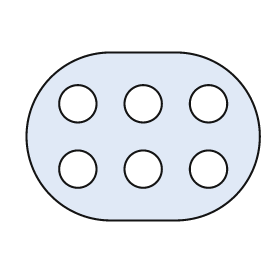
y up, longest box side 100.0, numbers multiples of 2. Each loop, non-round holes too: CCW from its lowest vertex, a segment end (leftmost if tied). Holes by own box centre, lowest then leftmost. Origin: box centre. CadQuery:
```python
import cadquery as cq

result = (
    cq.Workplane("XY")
    .moveTo(-14.0, -36.0)
    .lineTo(14.0, -36.0)
    .threePointArc((50.0, 0.0), (14.0, 36.0))
    .lineTo(-14.0, 36.0)
    .threePointArc((-50.0, 0.0), (-14.0, -36.0))
    .close()
    .moveTo(-28.0, -14.0)
    .circle(8.0)
    .moveTo(0.0, -14.0)
    .circle(8.0)
    .moveTo(28.0, -14.0)
    .circle(8.0)
    .moveTo(-28.0, 14.0)
    .circle(8.0)
    .moveTo(0.0, 14.0)
    .circle(8.0)
    .moveTo(28.0, 14.0)
    .circle(8.0)
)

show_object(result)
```